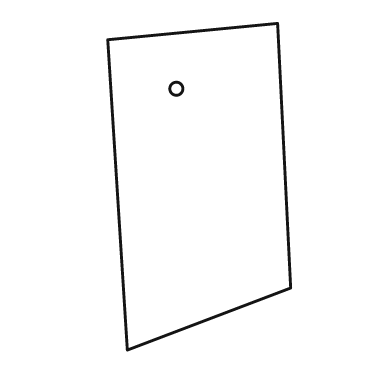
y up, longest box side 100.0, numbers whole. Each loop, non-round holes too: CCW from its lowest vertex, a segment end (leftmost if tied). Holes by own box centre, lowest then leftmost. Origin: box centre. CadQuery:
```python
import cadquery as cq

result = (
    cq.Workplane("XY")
    .moveTo(-22.0, -50.0)
    .lineTo(28.0, -31.0)
    .lineTo(24.0, 50.0)
    .lineTo(-28.0, 45.0)
    .close()
    .moveTo(-7.0, 30.0)
    .circle(2.0)
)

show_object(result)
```